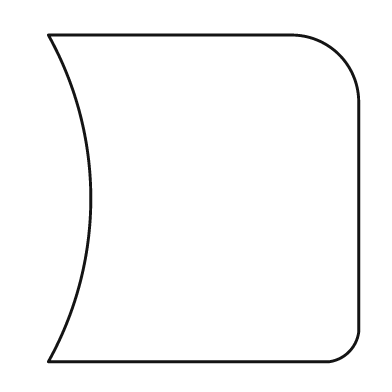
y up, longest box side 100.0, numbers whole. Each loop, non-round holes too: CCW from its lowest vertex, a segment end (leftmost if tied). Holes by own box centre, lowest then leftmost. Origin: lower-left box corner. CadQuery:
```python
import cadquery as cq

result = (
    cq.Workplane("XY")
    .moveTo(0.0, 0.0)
    .lineTo(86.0, 0.0)
    .threePointArc((92.0, 3.0), (95.0, 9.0))
    .lineTo(95.0, 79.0)
    .threePointArc((89.0, 94.0), (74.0, 100.0))
    .lineTo(0.0, 100.0)
    .threePointArc((13.0, 50.0), (0.0, 0.0))
    .close()
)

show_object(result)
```